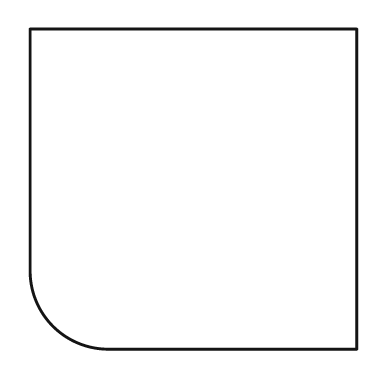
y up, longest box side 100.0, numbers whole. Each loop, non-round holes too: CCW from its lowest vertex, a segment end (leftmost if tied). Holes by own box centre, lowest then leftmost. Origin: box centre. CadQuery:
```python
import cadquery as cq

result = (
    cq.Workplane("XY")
    .moveTo(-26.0, -49.0)
    .lineTo(50.0, -49.0)
    .lineTo(50.0, 49.0)
    .lineTo(-50.0, 49.0)
    .lineTo(-50.0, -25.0)
    .threePointArc((-43.0, -42.0), (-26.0, -49.0))
    .close()
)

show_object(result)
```